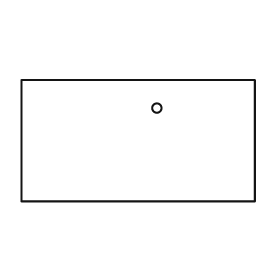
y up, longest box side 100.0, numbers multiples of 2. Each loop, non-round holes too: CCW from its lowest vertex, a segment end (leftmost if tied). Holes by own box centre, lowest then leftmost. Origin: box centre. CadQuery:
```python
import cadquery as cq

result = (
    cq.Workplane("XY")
    .moveTo(-50.0, -26.0)
    .lineTo(50.0, -26.0)
    .lineTo(50.0, 26.0)
    .lineTo(-50.0, 26.0)
    .close()
    .moveTo(8.0, 14.0)
    .circle(2.0)
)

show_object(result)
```